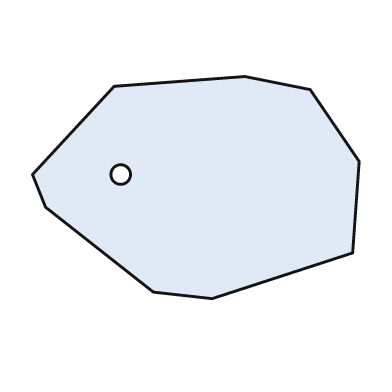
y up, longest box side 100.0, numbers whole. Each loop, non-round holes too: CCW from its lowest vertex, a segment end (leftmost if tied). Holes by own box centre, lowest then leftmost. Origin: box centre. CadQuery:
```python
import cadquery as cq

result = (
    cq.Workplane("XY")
    .moveTo(5.0, -34.0)
    .lineTo(48.0, -20.0)
    .lineTo(50.0, 8.0)
    .lineTo(35.0, 30.0)
    .lineTo(15.0, 34.0)
    .lineTo(-25.0, 31.0)
    .lineTo(-50.0, 4.0)
    .lineTo(-46.0, -6.0)
    .lineTo(-13.0, -32.0)
    .close()
    .moveTo(-23.0, 4.0)
    .circle(3.0)
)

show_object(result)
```